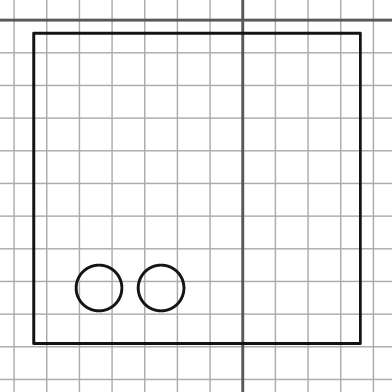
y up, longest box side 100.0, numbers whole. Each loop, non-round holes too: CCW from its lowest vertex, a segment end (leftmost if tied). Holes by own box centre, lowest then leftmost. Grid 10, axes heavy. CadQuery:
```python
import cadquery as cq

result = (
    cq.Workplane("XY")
    .moveTo(-64.0, -99.0)
    .lineTo(36.0, -99.0)
    .lineTo(36.0, -4.0)
    .lineTo(-64.0, -4.0)
    .close()
    .moveTo(-44.0, -82.0)
    .circle(7.0)
    .moveTo(-25.0, -82.0)
    .circle(7.0)
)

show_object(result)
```